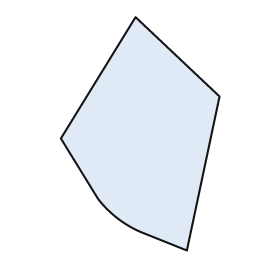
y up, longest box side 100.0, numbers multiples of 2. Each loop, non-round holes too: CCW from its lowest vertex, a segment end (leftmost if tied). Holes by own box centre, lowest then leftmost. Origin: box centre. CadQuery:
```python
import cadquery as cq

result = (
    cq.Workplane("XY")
    .moveTo(20.0, -50.0)
    .lineTo(34.0, 16.0)
    .lineTo(-2.0, 50.0)
    .lineTo(-34.0, -2.0)
    .lineTo(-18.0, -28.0)
    .threePointArc((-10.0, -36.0), (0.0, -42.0))
    .close()
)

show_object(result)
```